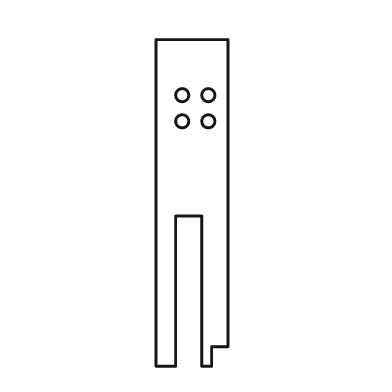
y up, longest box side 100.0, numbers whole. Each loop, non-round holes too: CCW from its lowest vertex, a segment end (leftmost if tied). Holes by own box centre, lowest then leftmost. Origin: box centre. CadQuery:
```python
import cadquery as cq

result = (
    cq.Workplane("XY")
    .moveTo(-11.0, -50.0)
    .lineTo(-5.0, -50.0)
    .lineTo(-5.0, -4.0)
    .lineTo(3.0, -4.0)
    .lineTo(3.0, -50.0)
    .lineTo(6.0, -50.0)
    .lineTo(6.0, -44.0)
    .lineTo(11.0, -44.0)
    .lineTo(11.0, 50.0)
    .lineTo(-11.0, 50.0)
    .close()
    .moveTo(-3.0, 25.0)
    .circle(2.0)
    .moveTo(5.0, 25.0)
    .circle(2.0)
    .moveTo(-3.0, 33.0)
    .circle(2.0)
    .moveTo(5.0, 33.0)
    .circle(2.0)
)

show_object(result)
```